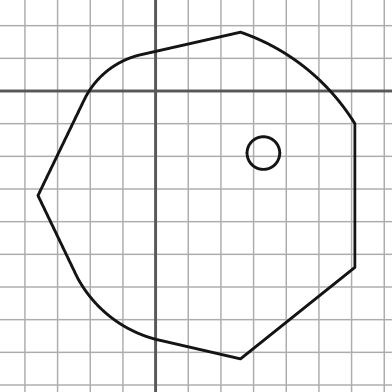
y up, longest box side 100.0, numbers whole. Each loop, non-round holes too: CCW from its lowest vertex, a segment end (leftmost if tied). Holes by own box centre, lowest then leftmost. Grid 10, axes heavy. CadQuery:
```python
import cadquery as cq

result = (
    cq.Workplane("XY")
    .moveTo(26.0, -82.0)
    .lineTo(61.0, -54.0)
    .lineTo(61.0, -10.0)
    .threePointArc((46.0, 7.0), (26.0, 18.0))
    .lineTo(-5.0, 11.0)
    .threePointArc((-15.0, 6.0), (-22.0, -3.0))
    .lineTo(-36.0, -32.0)
    .lineTo(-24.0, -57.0)
    .threePointArc((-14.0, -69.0), (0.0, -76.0))
    .close()
    .moveTo(33.0, -19.0)
    .circle(5.0)
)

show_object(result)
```